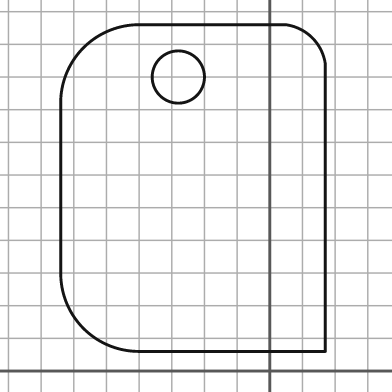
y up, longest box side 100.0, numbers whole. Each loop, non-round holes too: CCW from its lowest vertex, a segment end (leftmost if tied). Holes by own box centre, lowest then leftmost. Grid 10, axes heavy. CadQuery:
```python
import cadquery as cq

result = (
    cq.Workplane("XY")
    .moveTo(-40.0, 6.0)
    .lineTo(17.0, 6.0)
    .lineTo(17.0, 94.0)
    .threePointArc((13.0, 102.0), (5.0, 106.0))
    .lineTo(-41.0, 106.0)
    .threePointArc((-57.0, 99.0), (-64.0, 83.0))
    .lineTo(-64.0, 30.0)
    .threePointArc((-57.0, 13.0), (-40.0, 6.0))
    .close()
    .moveTo(-28.0, 90.0)
    .circle(8.0)
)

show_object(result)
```